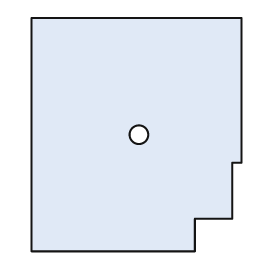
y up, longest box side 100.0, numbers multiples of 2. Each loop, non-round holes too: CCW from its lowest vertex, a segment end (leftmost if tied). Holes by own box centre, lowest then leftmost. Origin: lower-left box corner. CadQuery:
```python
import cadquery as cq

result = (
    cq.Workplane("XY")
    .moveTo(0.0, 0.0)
    .lineTo(70.0, 0.0)
    .lineTo(70.0, 14.0)
    .lineTo(86.0, 14.0)
    .lineTo(86.0, 38.0)
    .lineTo(90.0, 38.0)
    .lineTo(90.0, 100.0)
    .lineTo(0.0, 100.0)
    .close()
    .moveTo(46.0, 50.0)
    .circle(4.0)
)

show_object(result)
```